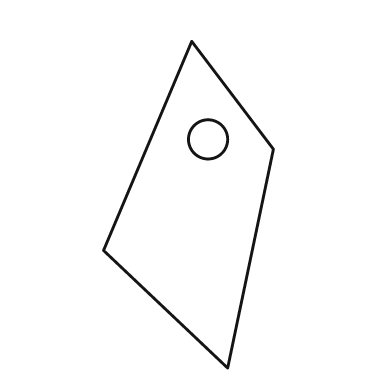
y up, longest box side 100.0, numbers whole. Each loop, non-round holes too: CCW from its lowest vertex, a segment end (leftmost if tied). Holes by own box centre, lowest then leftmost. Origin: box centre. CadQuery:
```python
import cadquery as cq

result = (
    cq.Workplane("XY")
    .moveTo(12.0, -50.0)
    .lineTo(26.0, 17.0)
    .lineTo(1.0, 50.0)
    .lineTo(-26.0, -14.0)
    .close()
    .moveTo(6.0, 20.0)
    .circle(6.0)
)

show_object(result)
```